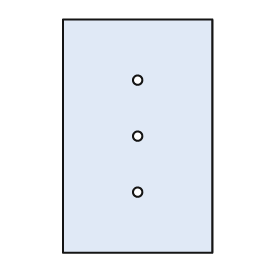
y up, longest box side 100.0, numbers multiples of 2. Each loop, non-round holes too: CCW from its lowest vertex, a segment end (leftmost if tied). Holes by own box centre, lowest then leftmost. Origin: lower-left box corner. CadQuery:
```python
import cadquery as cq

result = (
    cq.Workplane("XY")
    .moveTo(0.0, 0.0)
    .lineTo(64.0, 0.0)
    .lineTo(64.0, 100.0)
    .lineTo(0.0, 100.0)
    .close()
    .moveTo(32.0, 26.0)
    .circle(2.0)
    .moveTo(32.0, 50.0)
    .circle(2.0)
    .moveTo(32.0, 74.0)
    .circle(2.0)
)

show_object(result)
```